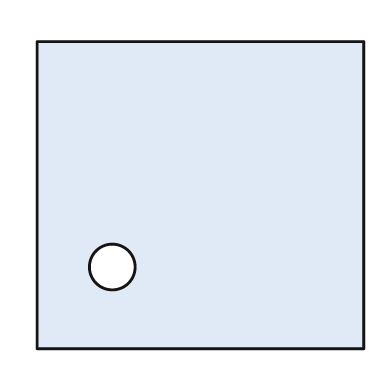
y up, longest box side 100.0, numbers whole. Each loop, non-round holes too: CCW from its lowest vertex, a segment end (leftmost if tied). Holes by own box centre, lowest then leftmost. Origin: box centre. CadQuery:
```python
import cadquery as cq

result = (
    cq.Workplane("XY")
    .moveTo(-50.0, -47.0)
    .lineTo(50.0, -47.0)
    .lineTo(50.0, 47.0)
    .lineTo(-50.0, 47.0)
    .close()
    .moveTo(-27.0, -22.0)
    .circle(7.0)
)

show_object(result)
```